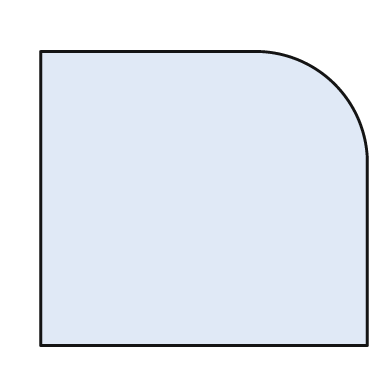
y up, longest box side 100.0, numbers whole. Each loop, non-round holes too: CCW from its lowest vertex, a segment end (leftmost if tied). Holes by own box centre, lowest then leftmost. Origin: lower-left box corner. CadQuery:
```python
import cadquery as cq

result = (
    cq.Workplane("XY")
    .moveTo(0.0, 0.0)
    .lineTo(100.0, 0.0)
    .lineTo(100.0, 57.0)
    .threePointArc((90.0, 80.0), (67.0, 90.0))
    .lineTo(0.0, 90.0)
    .close()
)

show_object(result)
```